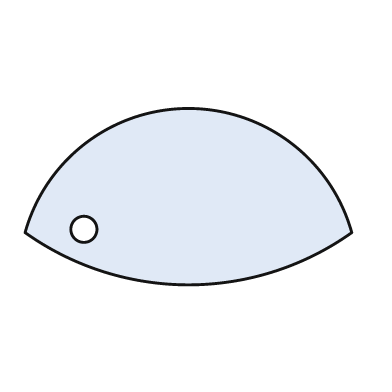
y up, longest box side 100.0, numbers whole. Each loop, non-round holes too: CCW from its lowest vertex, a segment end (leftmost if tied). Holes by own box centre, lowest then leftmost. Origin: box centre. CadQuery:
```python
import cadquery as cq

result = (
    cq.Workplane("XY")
    .moveTo(-50.0, -11.0)
    .threePointArc((0.0, -27.0), (50.0, -11.0))
    .threePointArc((0.0, 27.0), (-50.0, -11.0))
    .close()
    .moveTo(-32.0, -10.0)
    .circle(4.0)
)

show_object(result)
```